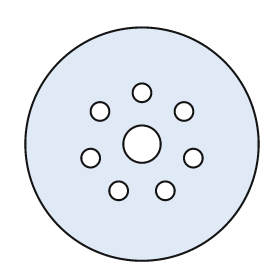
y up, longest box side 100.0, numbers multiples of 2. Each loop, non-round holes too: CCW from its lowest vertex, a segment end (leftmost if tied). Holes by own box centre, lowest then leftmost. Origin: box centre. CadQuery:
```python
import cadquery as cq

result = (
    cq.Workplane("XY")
    .moveTo(0.0, 0.0)
    .circle(50.0)
    .moveTo(-10.0, -20.0)
    .circle(4.0)
    .moveTo(10.0, -20.0)
    .circle(4.0)
    .moveTo(-22.0, -6.0)
    .circle(4.0)
    .moveTo(22.0, -6.0)
    .circle(4.0)
    .moveTo(0.0, 0.0)
    .circle(8.0)
    .moveTo(-18.0, 14.0)
    .circle(4.0)
    .moveTo(18.0, 14.0)
    .circle(4.0)
    .moveTo(0.0, 22.0)
    .circle(4.0)
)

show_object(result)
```